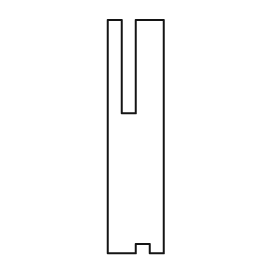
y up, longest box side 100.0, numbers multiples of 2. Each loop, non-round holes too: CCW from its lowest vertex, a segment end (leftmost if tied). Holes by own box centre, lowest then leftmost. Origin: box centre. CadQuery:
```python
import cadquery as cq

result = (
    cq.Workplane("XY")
    .moveTo(-12.0, -50.0)
    .lineTo(0.0, -50.0)
    .lineTo(0.0, -46.0)
    .lineTo(6.0, -46.0)
    .lineTo(6.0, -50.0)
    .lineTo(12.0, -50.0)
    .lineTo(12.0, 50.0)
    .lineTo(0.0, 50.0)
    .lineTo(0.0, 10.0)
    .lineTo(-6.0, 10.0)
    .lineTo(-6.0, 50.0)
    .lineTo(-12.0, 50.0)
    .close()
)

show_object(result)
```